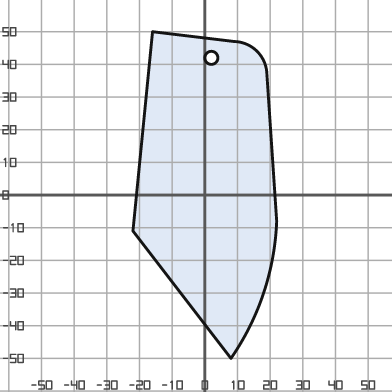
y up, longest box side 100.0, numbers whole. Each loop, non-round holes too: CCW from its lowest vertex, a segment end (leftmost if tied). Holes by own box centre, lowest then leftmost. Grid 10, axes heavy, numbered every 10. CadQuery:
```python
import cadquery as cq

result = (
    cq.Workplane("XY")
    .moveTo(8.0, -50.0)
    .threePointArc((18.0, -30.0), (22.0, -8.0))
    .lineTo(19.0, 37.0)
    .threePointArc((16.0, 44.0), (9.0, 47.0))
    .lineTo(-16.0, 50.0)
    .lineTo(-22.0, -11.0)
    .close()
    .moveTo(2.0, 42.0)
    .circle(2.0)
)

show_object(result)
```